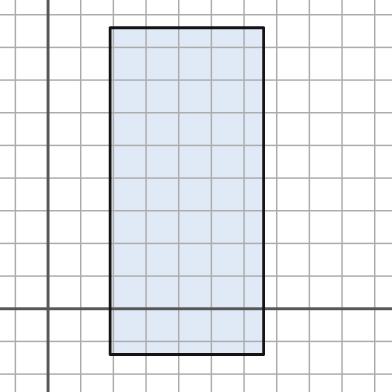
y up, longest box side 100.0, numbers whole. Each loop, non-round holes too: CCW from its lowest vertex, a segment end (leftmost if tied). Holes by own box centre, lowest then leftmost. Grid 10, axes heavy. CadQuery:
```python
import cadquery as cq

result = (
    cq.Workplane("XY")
    .moveTo(19.0, -14.0)
    .lineTo(66.0, -14.0)
    .lineTo(66.0, 86.0)
    .lineTo(19.0, 86.0)
    .close()
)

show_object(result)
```